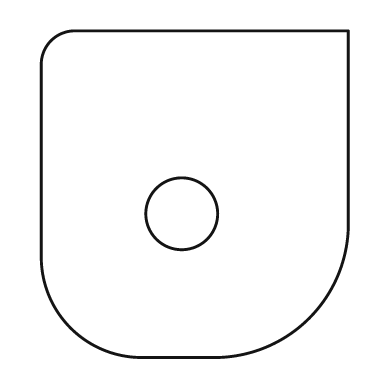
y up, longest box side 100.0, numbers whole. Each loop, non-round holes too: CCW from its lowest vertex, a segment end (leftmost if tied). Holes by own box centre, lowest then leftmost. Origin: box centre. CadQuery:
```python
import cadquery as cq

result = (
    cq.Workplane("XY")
    .moveTo(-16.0, -50.0)
    .lineTo(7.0, -50.0)
    .threePointArc((35.0, -38.0), (47.0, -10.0))
    .lineTo(47.0, 50.0)
    .lineTo(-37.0, 50.0)
    .threePointArc((-44.0, 47.0), (-47.0, 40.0))
    .lineTo(-47.0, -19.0)
    .threePointArc((-38.0, -41.0), (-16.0, -50.0))
    .close()
    .moveTo(-4.0, -6.0)
    .circle(11.0)
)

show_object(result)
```